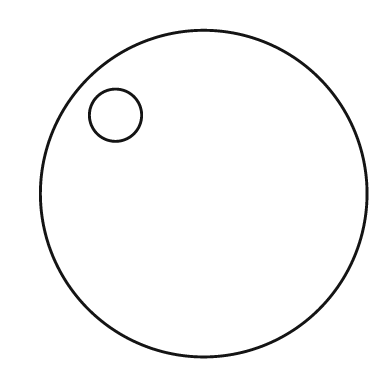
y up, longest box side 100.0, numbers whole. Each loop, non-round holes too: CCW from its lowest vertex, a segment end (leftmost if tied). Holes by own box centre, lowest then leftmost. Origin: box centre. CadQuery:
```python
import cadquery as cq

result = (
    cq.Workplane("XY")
    .moveTo(0.0, 0.0)
    .circle(50.0)
    .moveTo(-27.0, 24.0)
    .circle(8.0)
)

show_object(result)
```